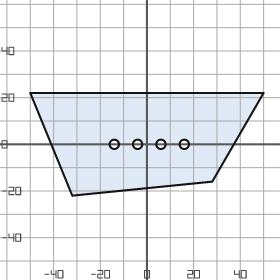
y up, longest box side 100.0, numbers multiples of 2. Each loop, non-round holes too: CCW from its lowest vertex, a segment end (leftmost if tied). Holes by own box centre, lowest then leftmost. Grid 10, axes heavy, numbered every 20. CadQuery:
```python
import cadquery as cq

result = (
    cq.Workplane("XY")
    .moveTo(-32.0, -22.0)
    .lineTo(28.0, -16.0)
    .lineTo(50.0, 22.0)
    .lineTo(-50.0, 22.0)
    .close()
    .moveTo(-14.0, 0.0)
    .circle(2.0)
    .moveTo(-4.0, 0.0)
    .circle(2.0)
    .moveTo(6.0, 0.0)
    .circle(2.0)
    .moveTo(16.0, 0.0)
    .circle(2.0)
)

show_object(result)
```